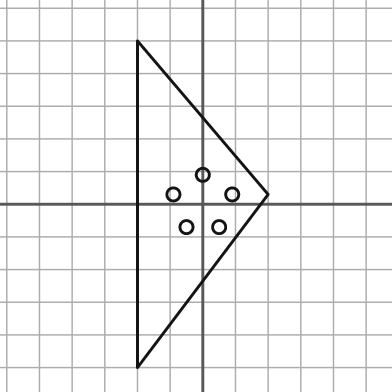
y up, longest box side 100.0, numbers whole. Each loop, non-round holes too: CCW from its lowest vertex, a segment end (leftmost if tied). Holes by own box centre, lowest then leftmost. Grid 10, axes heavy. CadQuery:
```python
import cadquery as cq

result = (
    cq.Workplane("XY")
    .moveTo(-20.0, -50.0)
    .lineTo(20.0, 3.0)
    .lineTo(-20.0, 50.0)
    .close()
    .moveTo(-5.0, -7.0)
    .circle(2.0)
    .moveTo(5.0, -7.0)
    .circle(2.0)
    .moveTo(-9.0, 3.0)
    .circle(2.0)
    .moveTo(9.0, 3.0)
    .circle(2.0)
    .moveTo(0.0, 9.0)
    .circle(2.0)
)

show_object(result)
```